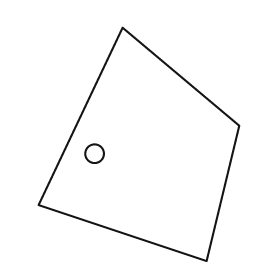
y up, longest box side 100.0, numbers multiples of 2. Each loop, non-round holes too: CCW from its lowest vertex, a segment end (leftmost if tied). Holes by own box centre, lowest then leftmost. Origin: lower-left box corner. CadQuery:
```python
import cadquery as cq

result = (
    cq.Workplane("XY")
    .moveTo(72.0, 0.0)
    .lineTo(86.0, 58.0)
    .lineTo(36.0, 100.0)
    .lineTo(0.0, 24.0)
    .close()
    .moveTo(24.0, 46.0)
    .circle(4.0)
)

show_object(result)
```